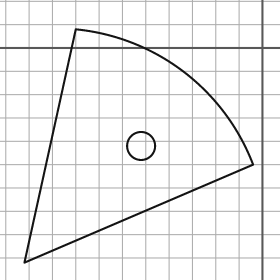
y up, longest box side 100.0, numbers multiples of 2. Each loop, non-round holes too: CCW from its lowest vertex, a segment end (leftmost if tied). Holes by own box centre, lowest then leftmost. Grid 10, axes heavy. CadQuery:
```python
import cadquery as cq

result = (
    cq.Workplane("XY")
    .moveTo(-102.0, -92.0)
    .lineTo(-4.0, -50.0)
    .threePointArc((-34.0, -10.0), (-80.0, 8.0))
    .close()
    .moveTo(-52.0, -42.0)
    .circle(6.0)
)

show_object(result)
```